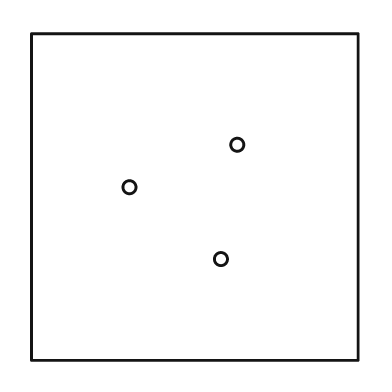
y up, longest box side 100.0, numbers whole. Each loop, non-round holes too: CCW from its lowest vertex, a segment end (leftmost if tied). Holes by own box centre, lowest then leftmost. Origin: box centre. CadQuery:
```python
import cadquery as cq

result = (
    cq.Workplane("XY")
    .moveTo(-50.0, -50.0)
    .lineTo(50.0, -50.0)
    .lineTo(50.0, 50.0)
    .lineTo(-50.0, 50.0)
    .close()
    .moveTo(8.0, -19.0)
    .circle(2.0)
    .moveTo(-20.0, 3.0)
    .circle(2.0)
    .moveTo(13.0, 16.0)
    .circle(2.0)
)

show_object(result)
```